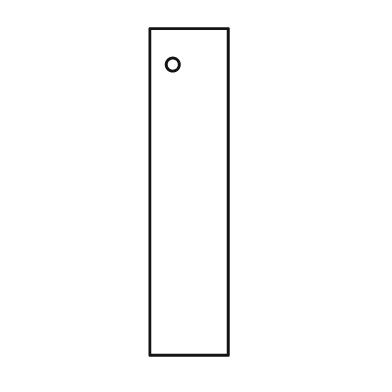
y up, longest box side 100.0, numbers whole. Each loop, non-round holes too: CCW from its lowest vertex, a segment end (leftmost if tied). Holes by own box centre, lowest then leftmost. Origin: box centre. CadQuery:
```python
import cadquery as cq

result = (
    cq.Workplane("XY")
    .moveTo(-12.0, -50.0)
    .lineTo(12.0, -50.0)
    .lineTo(12.0, 50.0)
    .lineTo(-12.0, 50.0)
    .close()
    .moveTo(-5.0, 39.0)
    .circle(2.0)
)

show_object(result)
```